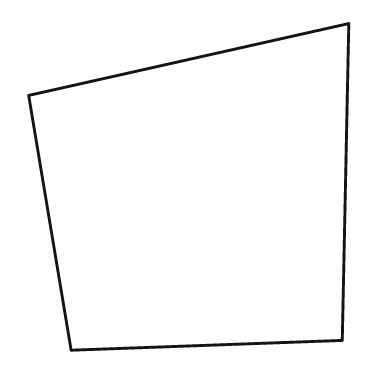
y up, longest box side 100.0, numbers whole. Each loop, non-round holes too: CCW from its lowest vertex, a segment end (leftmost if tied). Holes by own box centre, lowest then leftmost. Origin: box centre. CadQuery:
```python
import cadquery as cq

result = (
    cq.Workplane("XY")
    .moveTo(-36.0, -50.0)
    .lineTo(47.0, -47.0)
    .lineTo(49.0, 50.0)
    .lineTo(-49.0, 28.0)
    .close()
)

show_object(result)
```